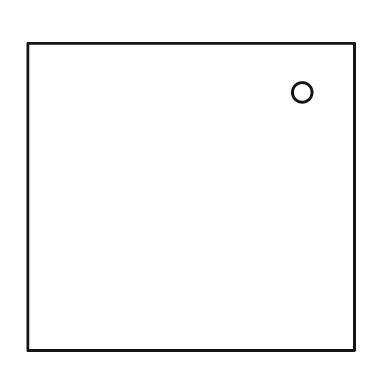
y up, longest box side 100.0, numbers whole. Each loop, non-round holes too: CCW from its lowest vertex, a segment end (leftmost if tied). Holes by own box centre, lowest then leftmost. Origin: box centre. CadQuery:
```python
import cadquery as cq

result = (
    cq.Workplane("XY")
    .moveTo(-50.0, -47.0)
    .lineTo(50.0, -47.0)
    .lineTo(50.0, 47.0)
    .lineTo(-50.0, 47.0)
    .close()
    .moveTo(34.0, 32.0)
    .circle(3.0)
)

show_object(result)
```